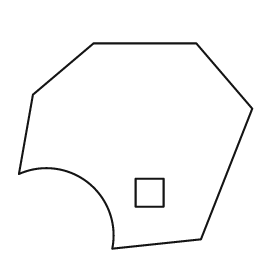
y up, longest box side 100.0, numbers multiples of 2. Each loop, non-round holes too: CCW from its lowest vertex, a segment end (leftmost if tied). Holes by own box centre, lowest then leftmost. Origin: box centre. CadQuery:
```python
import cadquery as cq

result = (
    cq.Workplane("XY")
    .moveTo(-10.0, -44.0)
    .lineTo(28.0, -40.0)
    .lineTo(50.0, 16.0)
    .lineTo(26.0, 44.0)
    .lineTo(-18.0, 44.0)
    .lineTo(-44.0, 22.0)
    .lineTo(-50.0, -12.0)
    .threePointArc((-20.0, -16.0), (-10.0, -44.0))
    .close()
    .moveTo(0.0, -26.0)
    .lineTo(12.0, -26.0)
    .lineTo(12.0, -14.0)
    .lineTo(0.0, -14.0)
    .close()
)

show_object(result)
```